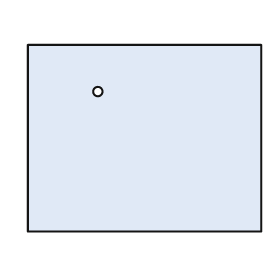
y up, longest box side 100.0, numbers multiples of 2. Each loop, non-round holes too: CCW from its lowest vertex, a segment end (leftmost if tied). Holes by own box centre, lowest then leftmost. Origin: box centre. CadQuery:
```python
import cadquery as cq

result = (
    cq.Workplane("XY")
    .moveTo(-50.0, -40.0)
    .lineTo(50.0, -40.0)
    .lineTo(50.0, 40.0)
    .lineTo(-50.0, 40.0)
    .close()
    .moveTo(-20.0, 20.0)
    .circle(2.0)
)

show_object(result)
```